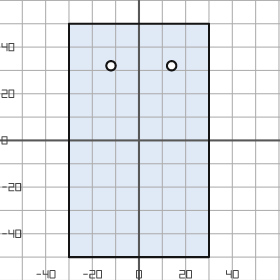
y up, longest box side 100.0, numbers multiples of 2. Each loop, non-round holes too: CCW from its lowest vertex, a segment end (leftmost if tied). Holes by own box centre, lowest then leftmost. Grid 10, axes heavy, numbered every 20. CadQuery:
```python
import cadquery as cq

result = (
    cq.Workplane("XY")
    .moveTo(-30.0, -50.0)
    .lineTo(30.0, -50.0)
    .lineTo(30.0, 50.0)
    .lineTo(-30.0, 50.0)
    .close()
    .moveTo(-12.0, 32.0)
    .circle(2.0)
    .moveTo(14.0, 32.0)
    .circle(2.0)
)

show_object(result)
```